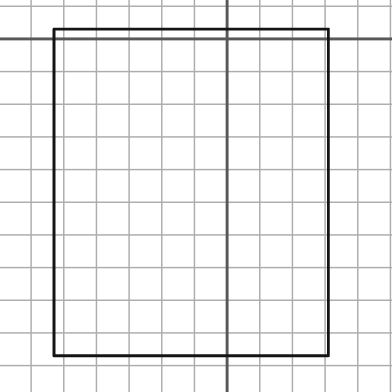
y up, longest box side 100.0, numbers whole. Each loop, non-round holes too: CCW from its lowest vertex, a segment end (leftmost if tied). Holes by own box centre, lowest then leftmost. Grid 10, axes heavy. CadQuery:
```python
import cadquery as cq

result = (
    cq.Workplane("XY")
    .moveTo(-53.0, -97.0)
    .lineTo(31.0, -97.0)
    .lineTo(31.0, 3.0)
    .lineTo(-53.0, 3.0)
    .close()
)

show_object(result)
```